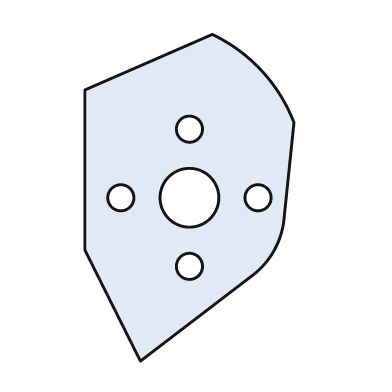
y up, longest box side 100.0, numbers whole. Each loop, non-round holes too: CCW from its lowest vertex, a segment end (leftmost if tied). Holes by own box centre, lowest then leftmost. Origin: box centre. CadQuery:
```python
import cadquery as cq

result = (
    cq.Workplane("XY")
    .moveTo(-15.0, -50.0)
    .lineTo(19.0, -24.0)
    .threePointArc((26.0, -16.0), (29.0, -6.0))
    .lineTo(32.0, 23.0)
    .threePointArc((22.0, 39.0), (7.0, 50.0))
    .lineTo(-32.0, 33.0)
    .lineTo(-32.0, -16.0)
    .close()
    .moveTo(0.0, -21.0)
    .circle(4.0)
    .moveTo(-21.0, 0.0)
    .circle(4.0)
    .moveTo(0.0, 0.0)
    .circle(9.0)
    .moveTo(21.0, 0.0)
    .circle(4.0)
    .moveTo(0.0, 21.0)
    .circle(4.0)
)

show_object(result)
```